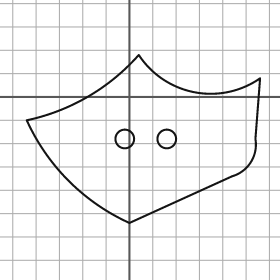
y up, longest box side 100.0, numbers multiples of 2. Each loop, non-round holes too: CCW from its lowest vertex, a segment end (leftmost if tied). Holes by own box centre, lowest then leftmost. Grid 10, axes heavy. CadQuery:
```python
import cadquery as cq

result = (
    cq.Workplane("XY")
    .moveTo(0.0, -54.0)
    .lineTo(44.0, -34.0)
    .threePointArc((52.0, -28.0), (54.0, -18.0))
    .lineTo(56.0, 8.0)
    .threePointArc((28.0, 2.0), (4.0, 18.0))
    .threePointArc((-18.0, 0.0), (-44.0, -10.0))
    .threePointArc((-26.0, -36.0), (0.0, -54.0))
    .close()
    .moveTo(-2.0, -18.0)
    .circle(4.0)
    .moveTo(16.0, -18.0)
    .circle(4.0)
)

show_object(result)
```